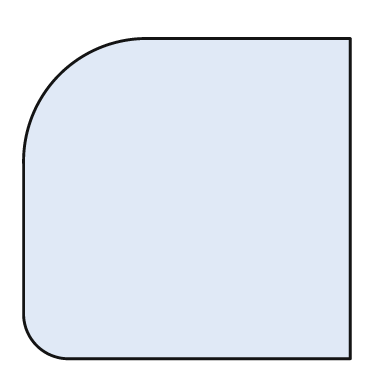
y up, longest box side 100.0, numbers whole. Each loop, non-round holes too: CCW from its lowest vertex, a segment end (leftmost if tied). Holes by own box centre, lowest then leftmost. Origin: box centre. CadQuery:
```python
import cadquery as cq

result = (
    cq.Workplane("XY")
    .moveTo(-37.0, -49.0)
    .lineTo(50.0, -49.0)
    .lineTo(50.0, 49.0)
    .lineTo(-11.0, 49.0)
    .threePointArc((-39.0, 38.0), (-50.0, 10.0))
    .lineTo(-50.0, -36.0)
    .threePointArc((-46.0, -45.0), (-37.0, -49.0))
    .close()
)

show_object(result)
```